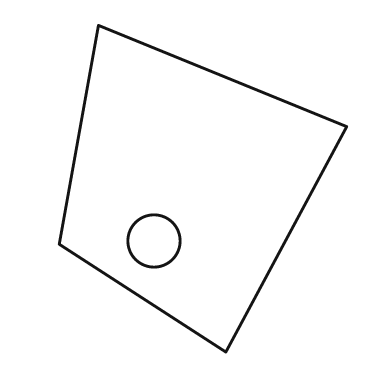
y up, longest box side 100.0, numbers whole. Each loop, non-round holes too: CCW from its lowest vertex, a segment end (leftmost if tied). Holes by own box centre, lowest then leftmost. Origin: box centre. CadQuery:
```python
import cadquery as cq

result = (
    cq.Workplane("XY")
    .moveTo(7.0, -50.0)
    .lineTo(44.0, 19.0)
    .lineTo(-32.0, 50.0)
    .lineTo(-44.0, -17.0)
    .close()
    .moveTo(-15.0, -16.0)
    .circle(8.0)
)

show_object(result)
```